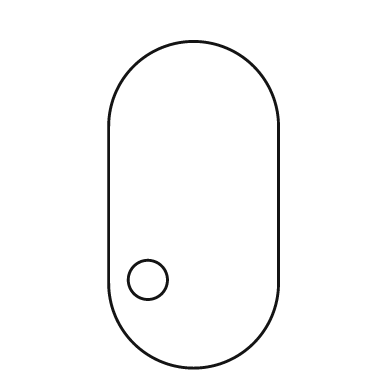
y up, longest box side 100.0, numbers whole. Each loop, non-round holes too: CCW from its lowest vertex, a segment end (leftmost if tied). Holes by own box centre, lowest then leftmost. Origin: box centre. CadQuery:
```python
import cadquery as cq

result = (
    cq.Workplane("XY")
    .moveTo(-26.0, -24.0)
    .threePointArc((0.0, -50.0), (26.0, -24.0))
    .lineTo(26.0, 24.0)
    .threePointArc((0.0, 50.0), (-26.0, 24.0))
    .close()
    .moveTo(-14.0, -23.0)
    .circle(6.0)
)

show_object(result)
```